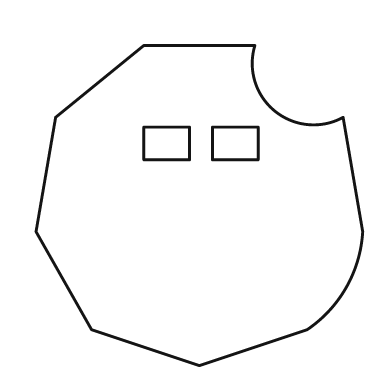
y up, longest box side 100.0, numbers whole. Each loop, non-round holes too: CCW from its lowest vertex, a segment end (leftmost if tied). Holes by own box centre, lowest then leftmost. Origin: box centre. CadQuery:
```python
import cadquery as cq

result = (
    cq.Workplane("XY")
    .moveTo(0.0, -49.0)
    .lineTo(33.0, -38.0)
    .threePointArc((45.0, -25.0), (50.0, -8.0))
    .lineTo(44.0, 27.0)
    .threePointArc((23.0, 29.0), (17.0, 49.0))
    .lineTo(-17.0, 49.0)
    .lineTo(-44.0, 27.0)
    .lineTo(-50.0, -8.0)
    .lineTo(-33.0, -38.0)
    .close()
    .moveTo(-17.0, 14.0)
    .lineTo(-3.0, 14.0)
    .lineTo(-3.0, 24.0)
    .lineTo(-17.0, 24.0)
    .close()
    .moveTo(4.0, 14.0)
    .lineTo(18.0, 14.0)
    .lineTo(18.0, 24.0)
    .lineTo(4.0, 24.0)
    .close()
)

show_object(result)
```